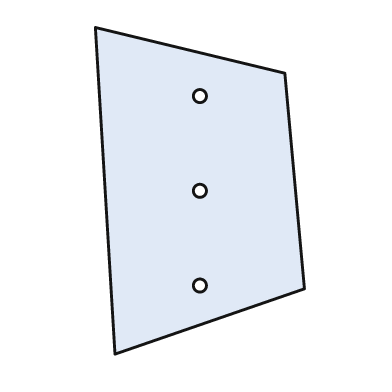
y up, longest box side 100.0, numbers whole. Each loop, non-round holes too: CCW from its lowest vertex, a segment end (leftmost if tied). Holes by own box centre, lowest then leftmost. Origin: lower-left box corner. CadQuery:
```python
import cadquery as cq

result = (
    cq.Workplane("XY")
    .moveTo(6.0, 0.0)
    .lineTo(64.0, 20.0)
    .lineTo(58.0, 86.0)
    .lineTo(0.0, 100.0)
    .close()
    .moveTo(32.0, 21.0)
    .circle(2.0)
    .moveTo(32.0, 50.0)
    .circle(2.0)
    .moveTo(32.0, 79.0)
    .circle(2.0)
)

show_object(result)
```